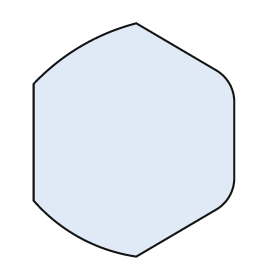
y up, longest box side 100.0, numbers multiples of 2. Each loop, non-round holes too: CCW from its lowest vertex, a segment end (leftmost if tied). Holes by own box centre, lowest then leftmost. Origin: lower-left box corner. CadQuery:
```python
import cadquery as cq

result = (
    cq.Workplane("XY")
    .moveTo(44.0, 0.0)
    .lineTo(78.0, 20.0)
    .threePointArc((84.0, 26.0), (86.0, 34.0))
    .lineTo(86.0, 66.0)
    .threePointArc((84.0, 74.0), (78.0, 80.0))
    .lineTo(44.0, 100.0)
    .threePointArc((20.0, 90.0), (0.0, 74.0))
    .lineTo(0.0, 24.0)
    .threePointArc((20.0, 8.0), (44.0, 0.0))
    .close()
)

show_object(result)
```